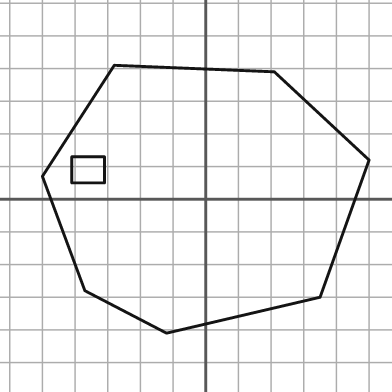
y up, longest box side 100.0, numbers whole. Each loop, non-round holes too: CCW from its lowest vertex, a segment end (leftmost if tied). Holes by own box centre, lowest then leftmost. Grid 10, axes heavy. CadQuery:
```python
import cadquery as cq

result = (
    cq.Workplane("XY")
    .moveTo(-12.0, -41.0)
    .lineTo(35.0, -30.0)
    .lineTo(50.0, 12.0)
    .lineTo(21.0, 39.0)
    .lineTo(-28.0, 41.0)
    .lineTo(-50.0, 7.0)
    .lineTo(-37.0, -28.0)
    .close()
    .moveTo(-41.0, 5.0)
    .lineTo(-31.0, 5.0)
    .lineTo(-31.0, 13.0)
    .lineTo(-41.0, 13.0)
    .close()
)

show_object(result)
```